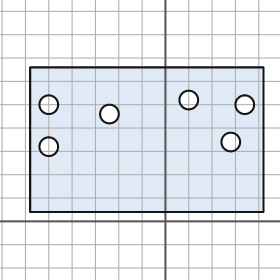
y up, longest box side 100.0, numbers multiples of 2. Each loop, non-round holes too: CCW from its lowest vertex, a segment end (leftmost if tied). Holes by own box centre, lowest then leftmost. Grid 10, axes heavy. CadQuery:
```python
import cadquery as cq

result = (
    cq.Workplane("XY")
    .moveTo(-58.0, 4.0)
    .lineTo(42.0, 4.0)
    .lineTo(42.0, 66.0)
    .lineTo(-58.0, 66.0)
    .close()
    .moveTo(-50.0, 32.0)
    .circle(4.0)
    .moveTo(28.0, 34.0)
    .circle(4.0)
    .moveTo(-24.0, 46.0)
    .circle(4.0)
    .moveTo(-50.0, 50.0)
    .circle(4.0)
    .moveTo(34.0, 50.0)
    .circle(4.0)
    .moveTo(10.0, 52.0)
    .circle(4.0)
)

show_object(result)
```